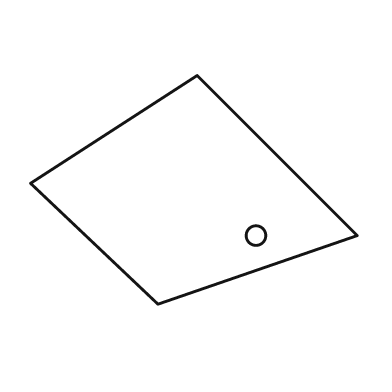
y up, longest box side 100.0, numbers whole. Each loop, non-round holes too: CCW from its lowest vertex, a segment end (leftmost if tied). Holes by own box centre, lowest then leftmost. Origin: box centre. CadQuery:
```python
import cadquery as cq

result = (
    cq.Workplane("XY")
    .moveTo(-11.0, -35.0)
    .lineTo(50.0, -14.0)
    .lineTo(1.0, 35.0)
    .lineTo(-50.0, 2.0)
    .close()
    .moveTo(19.0, -14.0)
    .circle(3.0)
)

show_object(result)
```